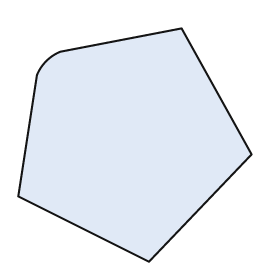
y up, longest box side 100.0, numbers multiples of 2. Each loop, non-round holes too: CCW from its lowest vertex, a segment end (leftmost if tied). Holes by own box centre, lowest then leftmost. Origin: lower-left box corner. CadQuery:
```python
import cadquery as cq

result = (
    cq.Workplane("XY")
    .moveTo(56.0, 0.0)
    .lineTo(100.0, 46.0)
    .lineTo(70.0, 100.0)
    .lineTo(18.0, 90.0)
    .threePointArc((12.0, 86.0), (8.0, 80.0))
    .lineTo(0.0, 28.0)
    .close()
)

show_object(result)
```